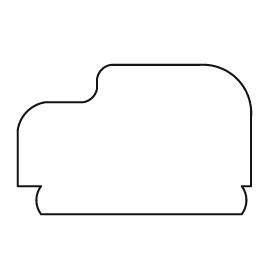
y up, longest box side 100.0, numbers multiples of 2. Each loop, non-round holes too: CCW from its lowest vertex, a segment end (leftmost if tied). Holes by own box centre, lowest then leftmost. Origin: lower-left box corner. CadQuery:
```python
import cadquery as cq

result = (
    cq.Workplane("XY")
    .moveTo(10.0, 0.0)
    .lineTo(96.0, 0.0)
    .threePointArc((98.0, 6.0), (96.0, 12.0))
    .lineTo(100.0, 12.0)
    .lineTo(100.0, 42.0)
    .threePointArc((94.0, 58.0), (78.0, 64.0))
    .lineTo(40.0, 64.0)
    .threePointArc((36.0, 62.0), (34.0, 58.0))
    .lineTo(34.0, 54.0)
    .threePointArc((32.0, 50.0), (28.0, 48.0))
    .lineTo(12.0, 48.0)
    .threePointArc((4.0, 44.0), (0.0, 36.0))
    .lineTo(0.0, 12.0)
    .lineTo(10.0, 12.0)
    .threePointArc((8.0, 6.0), (10.0, 0.0))
    .close()
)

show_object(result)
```